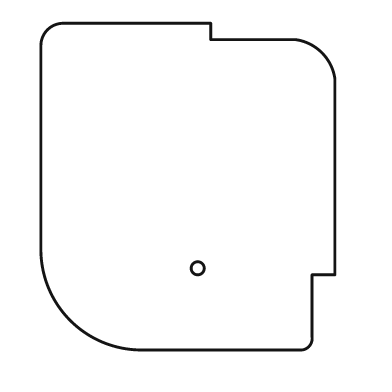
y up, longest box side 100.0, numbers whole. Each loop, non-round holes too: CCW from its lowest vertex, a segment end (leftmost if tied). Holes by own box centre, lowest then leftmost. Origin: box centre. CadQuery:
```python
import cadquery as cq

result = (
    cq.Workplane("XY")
    .moveTo(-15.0, -50.0)
    .lineTo(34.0, -50.0)
    .threePointArc((37.0, -49.0), (38.0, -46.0))
    .lineTo(38.0, -27.0)
    .lineTo(45.0, -27.0)
    .lineTo(45.0, 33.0)
    .threePointArc((41.0, 41.0), (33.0, 45.0))
    .lineTo(7.0, 45.0)
    .lineTo(7.0, 50.0)
    .lineTo(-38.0, 50.0)
    .threePointArc((-43.0, 48.0), (-45.0, 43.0))
    .lineTo(-45.0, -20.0)
    .threePointArc((-36.0, -41.0), (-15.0, -50.0))
    .close()
    .moveTo(3.0, -25.0)
    .circle(2.0)
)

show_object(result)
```